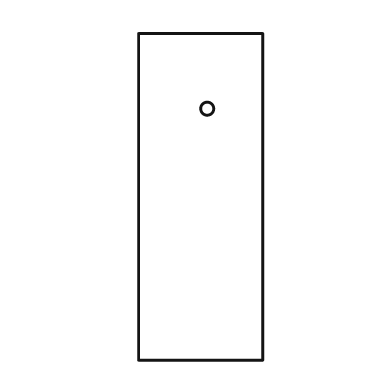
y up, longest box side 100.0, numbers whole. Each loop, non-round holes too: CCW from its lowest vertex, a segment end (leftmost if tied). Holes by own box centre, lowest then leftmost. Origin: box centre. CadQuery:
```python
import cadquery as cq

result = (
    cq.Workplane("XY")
    .moveTo(-19.0, -50.0)
    .lineTo(19.0, -50.0)
    .lineTo(19.0, 50.0)
    .lineTo(-19.0, 50.0)
    .close()
    .moveTo(2.0, 27.0)
    .circle(2.0)
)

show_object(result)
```